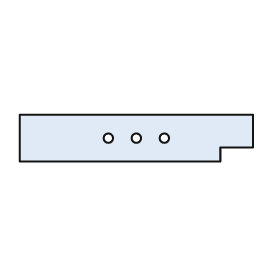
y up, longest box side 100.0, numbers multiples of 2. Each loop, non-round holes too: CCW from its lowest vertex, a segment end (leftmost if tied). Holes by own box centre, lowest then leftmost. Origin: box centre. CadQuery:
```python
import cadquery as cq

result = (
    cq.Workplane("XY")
    .moveTo(-50.0, -10.0)
    .lineTo(36.0, -10.0)
    .lineTo(36.0, -4.0)
    .lineTo(50.0, -4.0)
    .lineTo(50.0, 10.0)
    .lineTo(-50.0, 10.0)
    .close()
    .moveTo(-12.0, 0.0)
    .circle(2.0)
    .moveTo(0.0, 0.0)
    .circle(2.0)
    .moveTo(12.0, 0.0)
    .circle(2.0)
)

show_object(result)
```